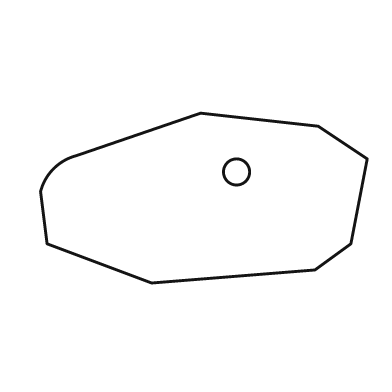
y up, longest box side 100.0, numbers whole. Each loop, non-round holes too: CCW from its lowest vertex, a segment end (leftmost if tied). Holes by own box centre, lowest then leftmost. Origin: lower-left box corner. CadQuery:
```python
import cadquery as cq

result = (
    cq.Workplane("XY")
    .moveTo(34.0, 0.0)
    .lineTo(84.0, 4.0)
    .lineTo(95.0, 12.0)
    .lineTo(100.0, 38.0)
    .lineTo(85.0, 48.0)
    .lineTo(49.0, 52.0)
    .lineTo(11.0, 39.0)
    .threePointArc((4.0, 35.0), (0.0, 28.0))
    .lineTo(2.0, 12.0)
    .close()
    .moveTo(60.0, 34.0)
    .circle(4.0)
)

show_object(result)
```